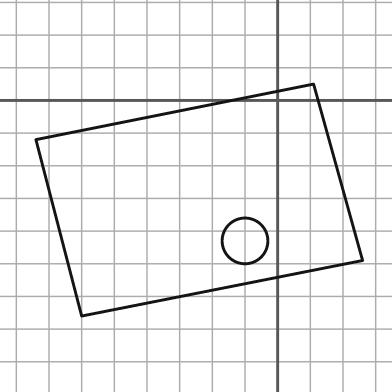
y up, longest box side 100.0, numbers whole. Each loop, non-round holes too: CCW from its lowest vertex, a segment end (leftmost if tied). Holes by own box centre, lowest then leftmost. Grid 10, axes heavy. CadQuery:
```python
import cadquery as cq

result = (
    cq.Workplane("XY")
    .moveTo(-60.0, -66.0)
    .lineTo(26.0, -49.0)
    .lineTo(11.0, 5.0)
    .lineTo(-74.0, -12.0)
    .close()
    .moveTo(-10.0, -43.0)
    .circle(7.0)
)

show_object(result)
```